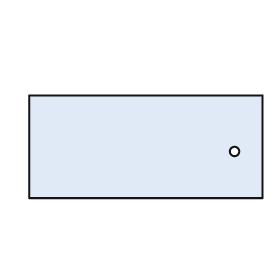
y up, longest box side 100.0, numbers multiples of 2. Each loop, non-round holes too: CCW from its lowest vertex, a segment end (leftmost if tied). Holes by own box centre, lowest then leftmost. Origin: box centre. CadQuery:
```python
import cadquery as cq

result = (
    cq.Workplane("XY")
    .moveTo(-50.0, -22.0)
    .lineTo(50.0, -22.0)
    .lineTo(50.0, 22.0)
    .lineTo(-50.0, 22.0)
    .close()
    .moveTo(38.0, -2.0)
    .circle(2.0)
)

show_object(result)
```